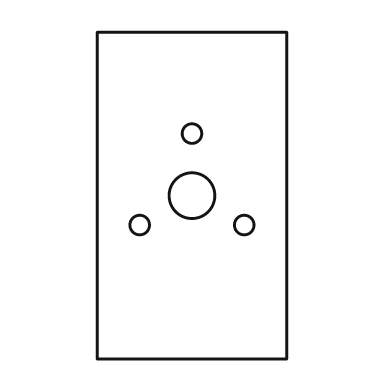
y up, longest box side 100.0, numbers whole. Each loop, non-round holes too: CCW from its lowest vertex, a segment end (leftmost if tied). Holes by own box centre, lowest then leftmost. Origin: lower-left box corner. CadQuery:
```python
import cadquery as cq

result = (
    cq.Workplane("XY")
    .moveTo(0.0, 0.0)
    .lineTo(58.0, 0.0)
    .lineTo(58.0, 100.0)
    .lineTo(0.0, 100.0)
    .close()
    .moveTo(13.0, 41.0)
    .circle(3.0)
    .moveTo(45.0, 41.0)
    .circle(3.0)
    .moveTo(29.0, 50.0)
    .circle(7.0)
    .moveTo(29.0, 69.0)
    .circle(3.0)
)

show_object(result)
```